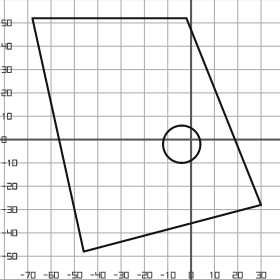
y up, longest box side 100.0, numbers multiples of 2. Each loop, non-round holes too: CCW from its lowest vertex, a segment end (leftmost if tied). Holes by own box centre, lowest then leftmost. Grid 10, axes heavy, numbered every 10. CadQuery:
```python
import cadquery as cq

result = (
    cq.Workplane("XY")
    .moveTo(-46.0, -48.0)
    .lineTo(30.0, -28.0)
    .lineTo(-2.0, 52.0)
    .lineTo(-68.0, 52.0)
    .close()
    .moveTo(-4.0, -2.0)
    .circle(8.0)
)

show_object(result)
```